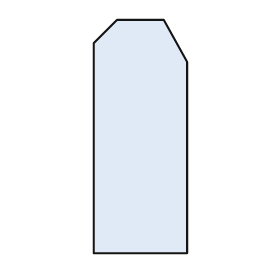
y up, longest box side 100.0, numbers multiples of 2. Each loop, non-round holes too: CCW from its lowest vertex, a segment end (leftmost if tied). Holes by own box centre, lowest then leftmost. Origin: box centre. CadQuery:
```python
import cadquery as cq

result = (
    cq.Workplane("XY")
    .moveTo(-20.0, -50.0)
    .lineTo(20.0, -50.0)
    .lineTo(20.0, 32.0)
    .lineTo(10.0, 50.0)
    .lineTo(-10.0, 50.0)
    .lineTo(-20.0, 40.0)
    .close()
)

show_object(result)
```